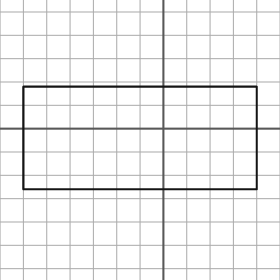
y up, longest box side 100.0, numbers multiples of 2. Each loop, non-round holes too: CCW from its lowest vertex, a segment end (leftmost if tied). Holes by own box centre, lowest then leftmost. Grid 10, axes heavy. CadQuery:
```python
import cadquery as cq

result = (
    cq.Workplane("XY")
    .moveTo(-60.0, -26.0)
    .lineTo(40.0, -26.0)
    .lineTo(40.0, 18.0)
    .lineTo(-60.0, 18.0)
    .close()
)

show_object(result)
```